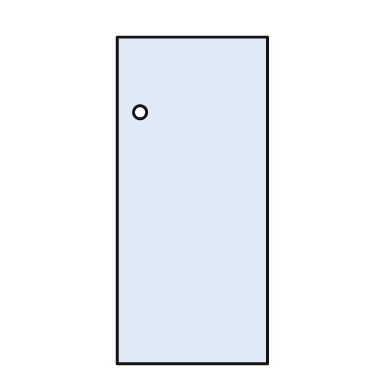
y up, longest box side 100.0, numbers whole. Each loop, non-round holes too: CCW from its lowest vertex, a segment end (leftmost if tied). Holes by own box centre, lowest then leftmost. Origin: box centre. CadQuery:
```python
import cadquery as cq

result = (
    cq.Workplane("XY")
    .moveTo(-23.0, -50.0)
    .lineTo(23.0, -50.0)
    .lineTo(23.0, 50.0)
    .lineTo(-23.0, 50.0)
    .close()
    .moveTo(-16.0, 27.0)
    .circle(2.0)
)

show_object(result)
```